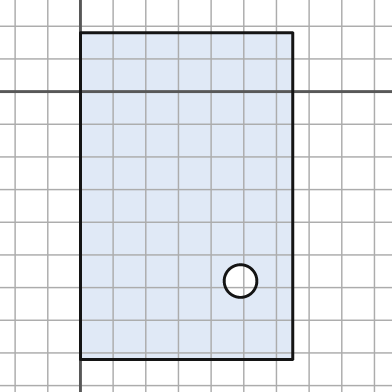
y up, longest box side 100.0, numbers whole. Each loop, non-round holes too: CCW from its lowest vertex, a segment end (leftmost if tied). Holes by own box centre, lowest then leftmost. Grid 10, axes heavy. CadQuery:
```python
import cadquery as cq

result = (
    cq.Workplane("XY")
    .moveTo(0.0, -82.0)
    .lineTo(65.0, -82.0)
    .lineTo(65.0, 18.0)
    .lineTo(0.0, 18.0)
    .close()
    .moveTo(49.0, -58.0)
    .circle(5.0)
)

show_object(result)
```